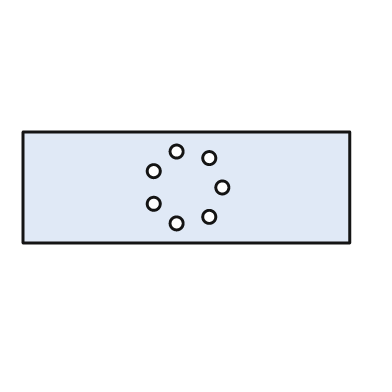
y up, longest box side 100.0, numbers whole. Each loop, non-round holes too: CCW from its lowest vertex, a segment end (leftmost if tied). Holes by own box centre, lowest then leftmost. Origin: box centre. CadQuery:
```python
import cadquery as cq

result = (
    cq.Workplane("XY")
    .moveTo(-50.0, -17.0)
    .lineTo(50.0, -17.0)
    .lineTo(50.0, 17.0)
    .lineTo(-50.0, 17.0)
    .close()
    .moveTo(-3.0, -11.0)
    .circle(2.0)
    .moveTo(7.0, -9.0)
    .circle(2.0)
    .moveTo(-10.0, -5.0)
    .circle(2.0)
    .moveTo(11.0, 0.0)
    .circle(2.0)
    .moveTo(-10.0, 5.0)
    .circle(2.0)
    .moveTo(7.0, 9.0)
    .circle(2.0)
    .moveTo(-3.0, 11.0)
    .circle(2.0)
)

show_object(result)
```